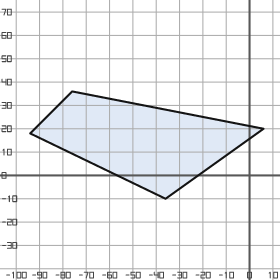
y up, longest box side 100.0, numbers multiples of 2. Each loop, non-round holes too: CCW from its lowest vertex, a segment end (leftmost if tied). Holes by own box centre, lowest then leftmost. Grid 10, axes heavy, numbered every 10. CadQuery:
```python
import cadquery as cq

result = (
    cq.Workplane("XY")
    .moveTo(-36.0, -10.0)
    .lineTo(6.0, 20.0)
    .lineTo(-76.0, 36.0)
    .lineTo(-94.0, 18.0)
    .close()
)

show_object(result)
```